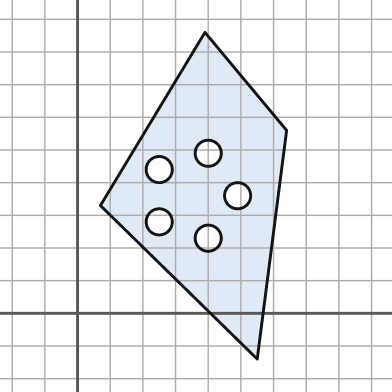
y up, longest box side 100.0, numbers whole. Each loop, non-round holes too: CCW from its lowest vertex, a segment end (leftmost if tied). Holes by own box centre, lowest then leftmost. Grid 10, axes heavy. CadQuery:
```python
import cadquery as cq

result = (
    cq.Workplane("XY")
    .moveTo(55.0, -14.0)
    .lineTo(64.0, 56.0)
    .lineTo(39.0, 86.0)
    .lineTo(7.0, 33.0)
    .close()
    .moveTo(40.0, 23.0)
    .circle(4.0)
    .moveTo(25.0, 28.0)
    .circle(4.0)
    .moveTo(49.0, 36.0)
    .circle(4.0)
    .moveTo(25.0, 44.0)
    .circle(4.0)
    .moveTo(40.0, 49.0)
    .circle(4.0)
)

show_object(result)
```